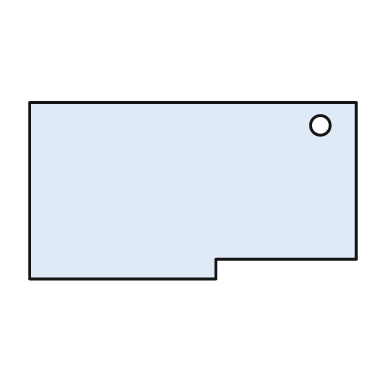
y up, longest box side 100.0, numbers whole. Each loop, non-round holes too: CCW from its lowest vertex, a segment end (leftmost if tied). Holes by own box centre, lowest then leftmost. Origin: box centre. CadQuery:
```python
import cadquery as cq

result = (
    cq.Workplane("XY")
    .moveTo(-50.0, -27.0)
    .lineTo(7.0, -27.0)
    .lineTo(7.0, -21.0)
    .lineTo(50.0, -21.0)
    .lineTo(50.0, 27.0)
    .lineTo(-50.0, 27.0)
    .close()
    .moveTo(39.0, 20.0)
    .circle(3.0)
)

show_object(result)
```